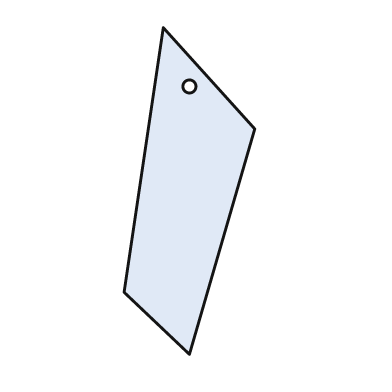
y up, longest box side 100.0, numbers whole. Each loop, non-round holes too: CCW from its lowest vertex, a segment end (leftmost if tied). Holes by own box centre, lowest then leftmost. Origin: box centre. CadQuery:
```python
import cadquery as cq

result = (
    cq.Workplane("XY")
    .moveTo(0.0, -50.0)
    .lineTo(20.0, 19.0)
    .lineTo(-8.0, 50.0)
    .lineTo(-20.0, -31.0)
    .close()
    .moveTo(0.0, 32.0)
    .circle(2.0)
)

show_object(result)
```